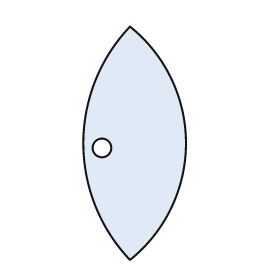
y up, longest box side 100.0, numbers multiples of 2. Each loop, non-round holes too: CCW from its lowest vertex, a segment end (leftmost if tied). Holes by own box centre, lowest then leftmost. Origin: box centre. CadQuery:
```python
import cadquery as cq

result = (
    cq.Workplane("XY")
    .moveTo(-2.0, -50.0)
    .threePointArc((22.0, 0.0), (-2.0, 50.0))
    .threePointArc((-22.0, 0.0), (-2.0, -50.0))
    .close()
    .moveTo(-14.0, -2.0)
    .circle(4.0)
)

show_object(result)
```